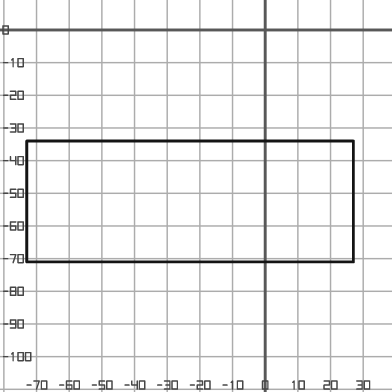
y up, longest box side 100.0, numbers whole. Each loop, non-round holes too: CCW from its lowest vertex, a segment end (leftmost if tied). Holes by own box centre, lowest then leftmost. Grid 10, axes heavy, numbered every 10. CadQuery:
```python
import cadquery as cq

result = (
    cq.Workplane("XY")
    .moveTo(-73.0, -71.0)
    .lineTo(27.0, -71.0)
    .lineTo(27.0, -34.0)
    .lineTo(-73.0, -34.0)
    .close()
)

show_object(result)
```